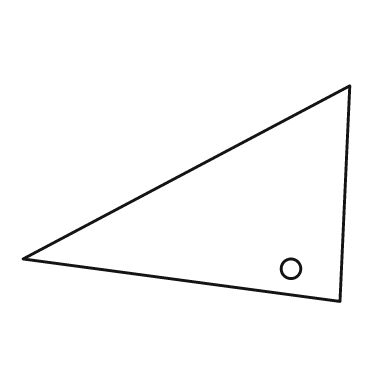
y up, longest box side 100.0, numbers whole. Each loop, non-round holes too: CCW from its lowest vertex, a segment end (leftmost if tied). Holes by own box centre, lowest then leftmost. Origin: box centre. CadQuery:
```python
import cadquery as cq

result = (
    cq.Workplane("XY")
    .moveTo(47.0, -33.0)
    .lineTo(50.0, 33.0)
    .lineTo(-50.0, -20.0)
    .close()
    .moveTo(32.0, -23.0)
    .circle(3.0)
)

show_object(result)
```